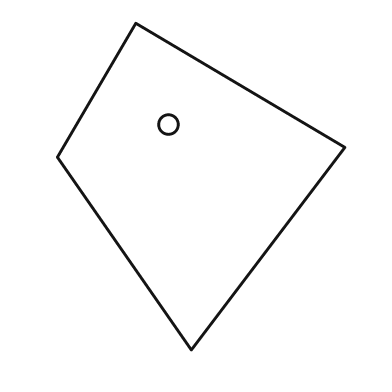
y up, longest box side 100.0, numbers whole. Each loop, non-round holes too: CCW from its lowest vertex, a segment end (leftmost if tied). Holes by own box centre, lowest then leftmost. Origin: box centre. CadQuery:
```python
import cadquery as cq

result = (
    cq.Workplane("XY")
    .moveTo(-3.0, -50.0)
    .lineTo(44.0, 12.0)
    .lineTo(-20.0, 50.0)
    .lineTo(-44.0, 9.0)
    .close()
    .moveTo(-10.0, 19.0)
    .circle(3.0)
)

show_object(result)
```